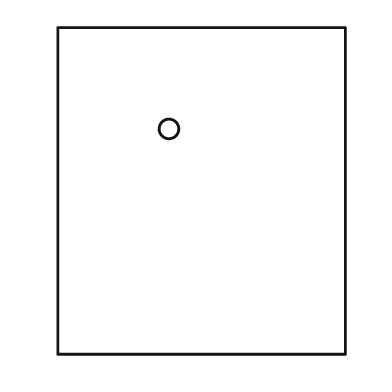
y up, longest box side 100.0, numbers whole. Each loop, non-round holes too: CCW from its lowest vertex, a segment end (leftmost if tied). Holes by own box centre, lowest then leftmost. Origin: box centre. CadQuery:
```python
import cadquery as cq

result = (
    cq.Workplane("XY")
    .moveTo(-44.0, -50.0)
    .lineTo(44.0, -50.0)
    .lineTo(44.0, 50.0)
    .lineTo(-44.0, 50.0)
    .close()
    .moveTo(-10.0, 19.0)
    .circle(3.0)
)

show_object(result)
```